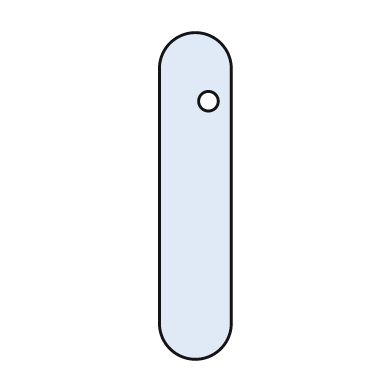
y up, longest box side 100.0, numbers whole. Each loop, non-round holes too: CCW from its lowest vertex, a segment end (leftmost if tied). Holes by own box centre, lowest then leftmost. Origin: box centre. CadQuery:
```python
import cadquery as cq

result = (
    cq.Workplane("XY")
    .moveTo(-11.0, -39.0)
    .threePointArc((0.0, -50.0), (11.0, -39.0))
    .lineTo(11.0, 39.0)
    .threePointArc((0.0, 50.0), (-11.0, 39.0))
    .close()
    .moveTo(4.0, 29.0)
    .circle(3.0)
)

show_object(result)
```